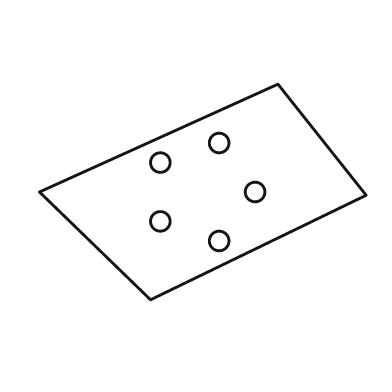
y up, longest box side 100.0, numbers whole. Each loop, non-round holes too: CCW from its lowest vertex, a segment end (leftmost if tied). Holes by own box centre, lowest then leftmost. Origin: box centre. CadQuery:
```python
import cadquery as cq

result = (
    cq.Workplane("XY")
    .moveTo(-16.0, -33.0)
    .lineTo(50.0, -1.0)
    .lineTo(23.0, 33.0)
    .lineTo(-50.0, 0.0)
    .close()
    .moveTo(5.0, -15.0)
    .circle(3.0)
    .moveTo(-13.0, -9.0)
    .circle(3.0)
    .moveTo(16.0, 0.0)
    .circle(3.0)
    .moveTo(-13.0, 9.0)
    .circle(3.0)
    .moveTo(5.0, 15.0)
    .circle(3.0)
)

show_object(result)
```